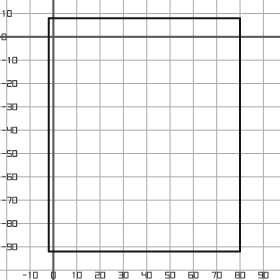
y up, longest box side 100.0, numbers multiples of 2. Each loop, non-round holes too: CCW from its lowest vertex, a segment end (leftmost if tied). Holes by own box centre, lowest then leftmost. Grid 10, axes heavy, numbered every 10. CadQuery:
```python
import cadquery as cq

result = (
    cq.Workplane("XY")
    .moveTo(-2.0, -92.0)
    .lineTo(80.0, -92.0)
    .lineTo(80.0, 8.0)
    .lineTo(-2.0, 8.0)
    .close()
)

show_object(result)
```